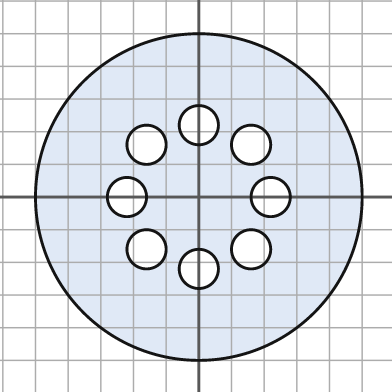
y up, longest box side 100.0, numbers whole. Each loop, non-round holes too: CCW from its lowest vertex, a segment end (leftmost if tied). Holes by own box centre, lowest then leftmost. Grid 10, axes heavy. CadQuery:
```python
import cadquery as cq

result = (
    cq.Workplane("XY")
    .moveTo(0.0, 0.0)
    .circle(50.0)
    .moveTo(0.0, -22.0)
    .circle(6.0)
    .moveTo(-16.0, -16.0)
    .circle(6.0)
    .moveTo(16.0, -16.0)
    .circle(6.0)
    .moveTo(-22.0, 0.0)
    .circle(6.0)
    .moveTo(22.0, 0.0)
    .circle(6.0)
    .moveTo(-16.0, 16.0)
    .circle(6.0)
    .moveTo(16.0, 16.0)
    .circle(6.0)
    .moveTo(0.0, 22.0)
    .circle(6.0)
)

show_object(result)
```